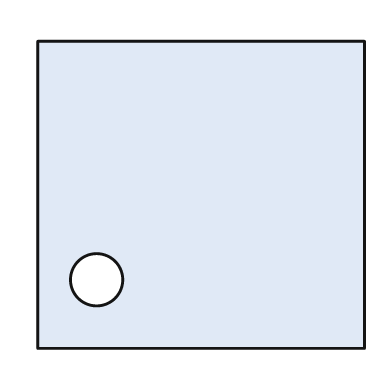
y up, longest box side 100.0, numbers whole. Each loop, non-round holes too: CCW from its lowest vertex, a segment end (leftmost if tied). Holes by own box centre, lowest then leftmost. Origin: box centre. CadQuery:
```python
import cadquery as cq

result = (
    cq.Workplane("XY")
    .moveTo(-50.0, -47.0)
    .lineTo(50.0, -47.0)
    .lineTo(50.0, 47.0)
    .lineTo(-50.0, 47.0)
    .close()
    .moveTo(-32.0, -26.0)
    .circle(8.0)
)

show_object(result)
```